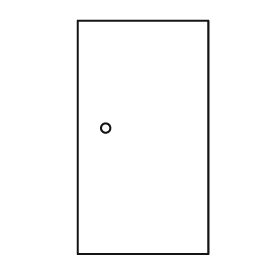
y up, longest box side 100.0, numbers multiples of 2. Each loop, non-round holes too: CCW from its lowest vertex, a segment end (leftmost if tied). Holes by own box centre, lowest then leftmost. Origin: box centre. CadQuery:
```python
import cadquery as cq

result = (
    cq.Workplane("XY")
    .moveTo(-28.0, -50.0)
    .lineTo(28.0, -50.0)
    .lineTo(28.0, 50.0)
    .lineTo(-28.0, 50.0)
    .close()
    .moveTo(-16.0, 4.0)
    .circle(2.0)
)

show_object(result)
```